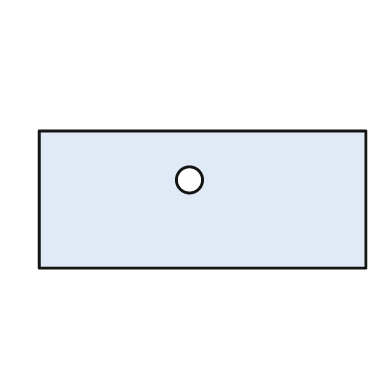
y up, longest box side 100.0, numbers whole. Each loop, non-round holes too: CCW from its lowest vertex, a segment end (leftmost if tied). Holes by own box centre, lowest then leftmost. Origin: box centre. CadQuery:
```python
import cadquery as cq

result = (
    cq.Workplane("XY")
    .moveTo(-50.0, -21.0)
    .lineTo(50.0, -21.0)
    .lineTo(50.0, 21.0)
    .lineTo(-50.0, 21.0)
    .close()
    .moveTo(-4.0, 6.0)
    .circle(4.0)
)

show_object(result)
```